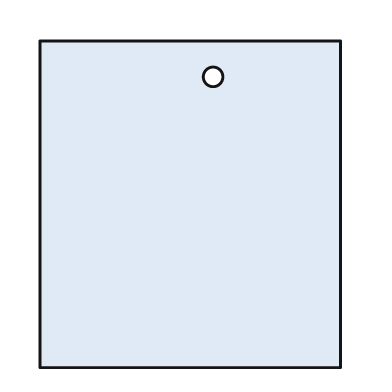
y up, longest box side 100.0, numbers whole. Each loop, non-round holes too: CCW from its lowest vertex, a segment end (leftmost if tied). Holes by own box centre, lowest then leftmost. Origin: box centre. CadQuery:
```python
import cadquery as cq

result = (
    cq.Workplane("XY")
    .moveTo(-46.0, -50.0)
    .lineTo(46.0, -50.0)
    .lineTo(46.0, 50.0)
    .lineTo(-46.0, 50.0)
    .close()
    .moveTo(7.0, 39.0)
    .circle(3.0)
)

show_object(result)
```